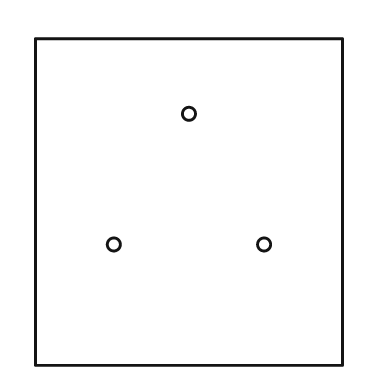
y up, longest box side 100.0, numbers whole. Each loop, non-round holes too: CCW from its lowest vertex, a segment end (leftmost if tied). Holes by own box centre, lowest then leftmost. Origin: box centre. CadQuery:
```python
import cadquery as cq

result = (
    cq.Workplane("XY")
    .moveTo(-47.0, -50.0)
    .lineTo(47.0, -50.0)
    .lineTo(47.0, 50.0)
    .lineTo(-47.0, 50.0)
    .close()
    .moveTo(-23.0, -13.0)
    .circle(2.0)
    .moveTo(23.0, -13.0)
    .circle(2.0)
    .moveTo(0.0, 27.0)
    .circle(2.0)
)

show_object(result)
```